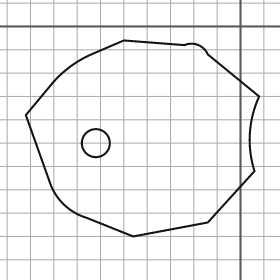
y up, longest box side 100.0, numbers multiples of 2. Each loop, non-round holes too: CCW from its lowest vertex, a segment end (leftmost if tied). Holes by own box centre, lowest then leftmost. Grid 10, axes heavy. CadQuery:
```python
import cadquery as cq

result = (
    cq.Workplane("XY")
    .moveTo(-46.0, -90.0)
    .lineTo(-14.0, -84.0)
    .lineTo(6.0, -62.0)
    .threePointArc((4.0, -46.0), (8.0, -30.0))
    .lineTo(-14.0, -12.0)
    .threePointArc((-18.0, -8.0), (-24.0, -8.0))
    .lineTo(-50.0, -6.0)
    .lineTo(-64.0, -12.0)
    .threePointArc((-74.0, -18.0), (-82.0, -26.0))
    .lineTo(-92.0, -38.0)
    .lineTo(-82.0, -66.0)
    .threePointArc((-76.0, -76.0), (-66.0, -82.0))
    .close()
    .moveTo(-62.0, -50.0)
    .circle(6.0)
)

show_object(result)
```